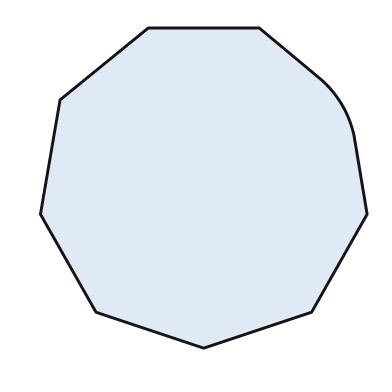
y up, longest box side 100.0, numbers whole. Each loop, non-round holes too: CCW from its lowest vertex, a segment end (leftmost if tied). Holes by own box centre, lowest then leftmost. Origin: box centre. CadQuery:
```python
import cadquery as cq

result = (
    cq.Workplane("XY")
    .moveTo(0.0, -49.0)
    .lineTo(33.0, -38.0)
    .lineTo(50.0, -8.0)
    .lineTo(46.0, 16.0)
    .threePointArc((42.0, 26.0), (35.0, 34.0))
    .lineTo(17.0, 49.0)
    .lineTo(-17.0, 49.0)
    .lineTo(-44.0, 27.0)
    .lineTo(-50.0, -8.0)
    .lineTo(-33.0, -38.0)
    .close()
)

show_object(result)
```